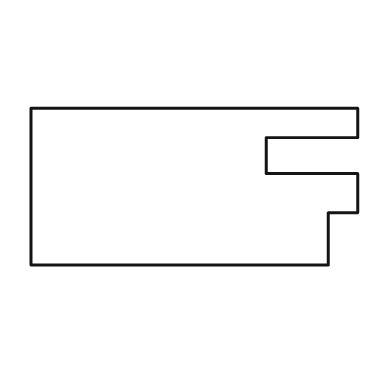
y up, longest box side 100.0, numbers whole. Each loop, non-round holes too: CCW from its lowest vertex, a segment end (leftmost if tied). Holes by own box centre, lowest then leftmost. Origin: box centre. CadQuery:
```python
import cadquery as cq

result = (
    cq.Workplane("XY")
    .moveTo(-50.0, -24.0)
    .lineTo(41.0, -24.0)
    .lineTo(41.0, -8.0)
    .lineTo(50.0, -8.0)
    .lineTo(50.0, 4.0)
    .lineTo(22.0, 4.0)
    .lineTo(22.0, 15.0)
    .lineTo(50.0, 15.0)
    .lineTo(50.0, 24.0)
    .lineTo(-50.0, 24.0)
    .close()
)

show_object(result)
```